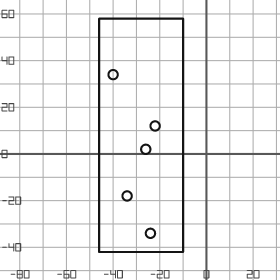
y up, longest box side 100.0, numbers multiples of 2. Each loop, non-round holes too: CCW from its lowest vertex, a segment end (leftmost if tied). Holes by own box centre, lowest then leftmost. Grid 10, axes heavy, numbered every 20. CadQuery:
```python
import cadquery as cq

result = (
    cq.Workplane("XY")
    .moveTo(-46.0, -42.0)
    .lineTo(-10.0, -42.0)
    .lineTo(-10.0, 58.0)
    .lineTo(-46.0, 58.0)
    .close()
    .moveTo(-24.0, -34.0)
    .circle(2.0)
    .moveTo(-34.0, -18.0)
    .circle(2.0)
    .moveTo(-26.0, 2.0)
    .circle(2.0)
    .moveTo(-22.0, 12.0)
    .circle(2.0)
    .moveTo(-40.0, 34.0)
    .circle(2.0)
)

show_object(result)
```